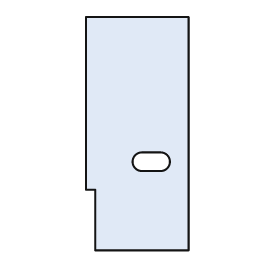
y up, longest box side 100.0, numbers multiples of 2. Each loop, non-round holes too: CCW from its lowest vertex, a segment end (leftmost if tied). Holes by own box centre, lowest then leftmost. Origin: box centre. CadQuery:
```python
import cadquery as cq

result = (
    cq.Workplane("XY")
    .moveTo(-18.0, -50.0)
    .lineTo(22.0, -50.0)
    .lineTo(22.0, 50.0)
    .lineTo(-22.0, 50.0)
    .lineTo(-22.0, -24.0)
    .lineTo(-18.0, -24.0)
    .close()
    .moveTo(2.0, -16.0)
    .lineTo(10.0, -16.0)
    .threePointArc((14.0, -12.0), (10.0, -8.0))
    .lineTo(2.0, -8.0)
    .threePointArc((-2.0, -12.0), (2.0, -16.0))
    .close()
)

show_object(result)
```